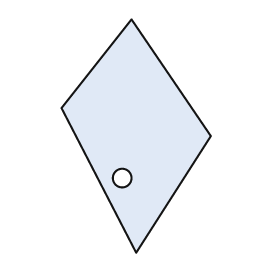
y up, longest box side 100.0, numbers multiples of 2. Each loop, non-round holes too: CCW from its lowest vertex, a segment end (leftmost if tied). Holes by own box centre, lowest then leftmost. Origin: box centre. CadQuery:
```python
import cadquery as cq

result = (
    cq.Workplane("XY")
    .moveTo(0.0, -50.0)
    .lineTo(32.0, 0.0)
    .lineTo(-2.0, 50.0)
    .lineTo(-32.0, 12.0)
    .close()
    .moveTo(-6.0, -18.0)
    .circle(4.0)
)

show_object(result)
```